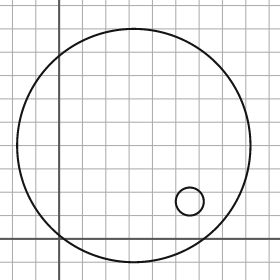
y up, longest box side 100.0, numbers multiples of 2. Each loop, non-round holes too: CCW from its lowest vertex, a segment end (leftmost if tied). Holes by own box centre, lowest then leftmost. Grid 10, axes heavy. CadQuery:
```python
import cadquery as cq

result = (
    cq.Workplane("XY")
    .moveTo(32.0, 40.0)
    .circle(50.0)
    .moveTo(56.0, 16.0)
    .circle(6.0)
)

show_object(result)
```